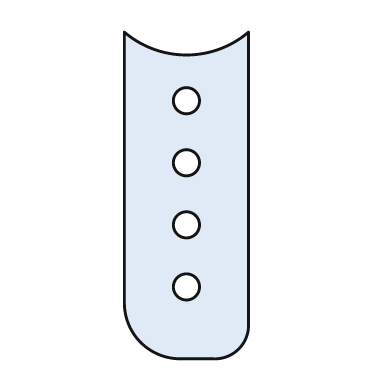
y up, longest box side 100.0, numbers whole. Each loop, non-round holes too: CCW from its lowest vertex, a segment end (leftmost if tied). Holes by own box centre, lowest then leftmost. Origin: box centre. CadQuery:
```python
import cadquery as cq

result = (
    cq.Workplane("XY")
    .moveTo(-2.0, -50.0)
    .lineTo(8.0, -50.0)
    .threePointArc((16.0, -47.0), (19.0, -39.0))
    .lineTo(19.0, 50.0)
    .threePointArc((0.0, 43.0), (-19.0, 50.0))
    .lineTo(-19.0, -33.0)
    .threePointArc((-14.0, -45.0), (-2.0, -50.0))
    .close()
    .moveTo(0.0, -28.0)
    .circle(4.0)
    .moveTo(0.0, -9.0)
    .circle(4.0)
    .moveTo(0.0, 10.0)
    .circle(4.0)
    .moveTo(0.0, 29.0)
    .circle(4.0)
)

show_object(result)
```